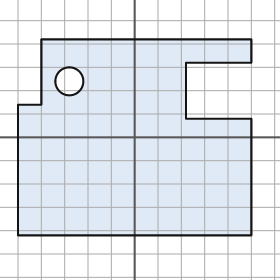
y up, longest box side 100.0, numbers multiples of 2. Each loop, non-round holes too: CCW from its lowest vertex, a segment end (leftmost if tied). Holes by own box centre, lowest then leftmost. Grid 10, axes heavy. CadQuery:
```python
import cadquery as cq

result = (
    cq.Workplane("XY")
    .moveTo(-50.0, -42.0)
    .lineTo(50.0, -42.0)
    .lineTo(50.0, 8.0)
    .lineTo(22.0, 8.0)
    .lineTo(22.0, 32.0)
    .lineTo(50.0, 32.0)
    .lineTo(50.0, 42.0)
    .lineTo(-40.0, 42.0)
    .lineTo(-40.0, 14.0)
    .lineTo(-50.0, 14.0)
    .close()
    .moveTo(-28.0, 24.0)
    .circle(6.0)
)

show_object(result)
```